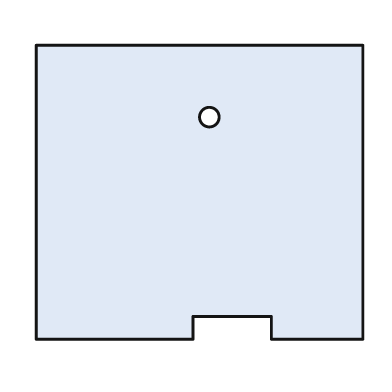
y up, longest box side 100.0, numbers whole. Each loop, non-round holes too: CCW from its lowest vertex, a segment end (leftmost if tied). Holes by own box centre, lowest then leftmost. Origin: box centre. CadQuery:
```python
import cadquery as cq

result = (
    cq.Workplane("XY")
    .moveTo(-50.0, -45.0)
    .lineTo(-2.0, -45.0)
    .lineTo(-2.0, -38.0)
    .lineTo(22.0, -38.0)
    .lineTo(22.0, -45.0)
    .lineTo(50.0, -45.0)
    .lineTo(50.0, 45.0)
    .lineTo(-50.0, 45.0)
    .close()
    .moveTo(3.0, 23.0)
    .circle(3.0)
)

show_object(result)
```